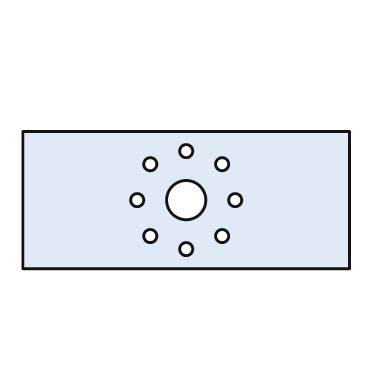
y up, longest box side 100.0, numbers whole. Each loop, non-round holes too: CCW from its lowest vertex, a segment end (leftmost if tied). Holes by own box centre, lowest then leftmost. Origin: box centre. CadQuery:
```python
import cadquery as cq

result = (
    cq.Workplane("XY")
    .moveTo(-50.0, -21.0)
    .lineTo(50.0, -21.0)
    .lineTo(50.0, 21.0)
    .lineTo(-50.0, 21.0)
    .close()
    .moveTo(0.0, -15.0)
    .circle(2.0)
    .moveTo(-11.0, -11.0)
    .circle(2.0)
    .moveTo(11.0, -11.0)
    .circle(2.0)
    .moveTo(-15.0, 0.0)
    .circle(2.0)
    .moveTo(0.0, 0.0)
    .circle(6.0)
    .moveTo(15.0, 0.0)
    .circle(2.0)
    .moveTo(-11.0, 11.0)
    .circle(2.0)
    .moveTo(11.0, 11.0)
    .circle(2.0)
    .moveTo(0.0, 15.0)
    .circle(2.0)
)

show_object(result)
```